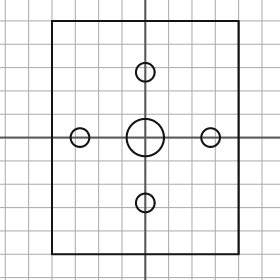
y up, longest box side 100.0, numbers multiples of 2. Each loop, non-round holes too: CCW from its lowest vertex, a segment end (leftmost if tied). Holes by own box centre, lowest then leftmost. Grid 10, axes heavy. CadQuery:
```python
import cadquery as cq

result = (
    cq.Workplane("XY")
    .moveTo(-40.0, -50.0)
    .lineTo(40.0, -50.0)
    .lineTo(40.0, 50.0)
    .lineTo(-40.0, 50.0)
    .close()
    .moveTo(0.0, -28.0)
    .circle(4.0)
    .moveTo(-28.0, 0.0)
    .circle(4.0)
    .moveTo(0.0, 0.0)
    .circle(8.0)
    .moveTo(28.0, 0.0)
    .circle(4.0)
    .moveTo(0.0, 28.0)
    .circle(4.0)
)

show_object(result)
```